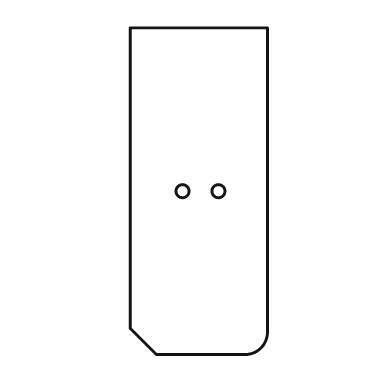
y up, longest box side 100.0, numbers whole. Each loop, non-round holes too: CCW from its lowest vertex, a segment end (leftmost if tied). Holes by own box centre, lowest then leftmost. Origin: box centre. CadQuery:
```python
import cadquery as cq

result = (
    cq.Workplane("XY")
    .moveTo(-13.0, -50.0)
    .lineTo(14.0, -50.0)
    .threePointArc((19.0, -48.0), (21.0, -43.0))
    .lineTo(21.0, 50.0)
    .lineTo(-21.0, 50.0)
    .lineTo(-21.0, -42.0)
    .close()
    .moveTo(-5.0, 0.0)
    .circle(2.0)
    .moveTo(6.0, 0.0)
    .circle(2.0)
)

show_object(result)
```